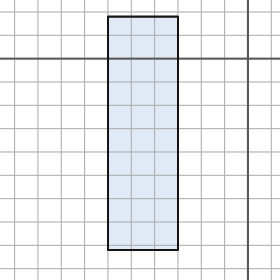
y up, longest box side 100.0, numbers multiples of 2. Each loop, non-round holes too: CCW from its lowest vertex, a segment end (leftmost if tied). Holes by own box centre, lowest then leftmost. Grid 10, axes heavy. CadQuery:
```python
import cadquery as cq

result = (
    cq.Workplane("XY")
    .moveTo(-60.0, -82.0)
    .lineTo(-30.0, -82.0)
    .lineTo(-30.0, 18.0)
    .lineTo(-60.0, 18.0)
    .close()
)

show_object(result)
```